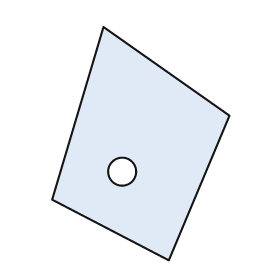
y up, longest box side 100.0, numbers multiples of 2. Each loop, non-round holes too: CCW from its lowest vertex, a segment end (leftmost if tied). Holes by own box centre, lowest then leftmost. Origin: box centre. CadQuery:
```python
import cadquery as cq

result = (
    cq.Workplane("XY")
    .moveTo(12.0, -50.0)
    .lineTo(38.0, 12.0)
    .lineTo(-16.0, 50.0)
    .lineTo(-38.0, -24.0)
    .close()
    .moveTo(-8.0, -12.0)
    .circle(6.0)
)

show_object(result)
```